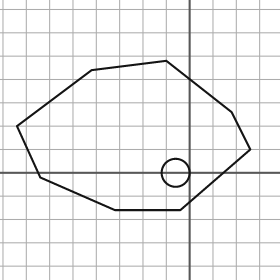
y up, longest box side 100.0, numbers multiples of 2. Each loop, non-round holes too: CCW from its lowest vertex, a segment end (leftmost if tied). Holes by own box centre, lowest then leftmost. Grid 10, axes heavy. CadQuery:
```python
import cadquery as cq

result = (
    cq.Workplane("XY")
    .moveTo(-32.0, -16.0)
    .lineTo(-4.0, -16.0)
    .lineTo(26.0, 10.0)
    .lineTo(18.0, 26.0)
    .lineTo(-10.0, 48.0)
    .lineTo(-42.0, 44.0)
    .lineTo(-74.0, 20.0)
    .lineTo(-64.0, -2.0)
    .close()
    .moveTo(-6.0, 0.0)
    .circle(6.0)
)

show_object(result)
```